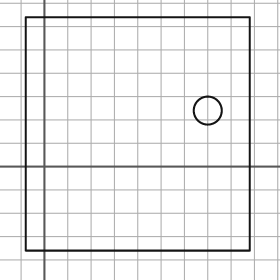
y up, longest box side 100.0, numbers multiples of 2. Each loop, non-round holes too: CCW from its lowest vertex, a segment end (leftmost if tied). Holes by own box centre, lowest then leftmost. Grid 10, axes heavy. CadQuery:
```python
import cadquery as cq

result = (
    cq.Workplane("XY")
    .moveTo(-8.0, -36.0)
    .lineTo(88.0, -36.0)
    .lineTo(88.0, 64.0)
    .lineTo(-8.0, 64.0)
    .close()
    .moveTo(70.0, 24.0)
    .circle(6.0)
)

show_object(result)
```